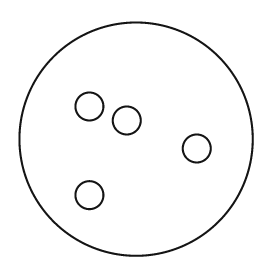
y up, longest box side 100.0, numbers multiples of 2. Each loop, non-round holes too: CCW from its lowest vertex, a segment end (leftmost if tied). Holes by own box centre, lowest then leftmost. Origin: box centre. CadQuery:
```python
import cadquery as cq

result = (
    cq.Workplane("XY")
    .moveTo(0.0, 0.0)
    .circle(50.0)
    .moveTo(-20.0, -24.0)
    .circle(6.0)
    .moveTo(26.0, -4.0)
    .circle(6.0)
    .moveTo(-4.0, 8.0)
    .circle(6.0)
    .moveTo(-20.0, 14.0)
    .circle(6.0)
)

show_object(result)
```